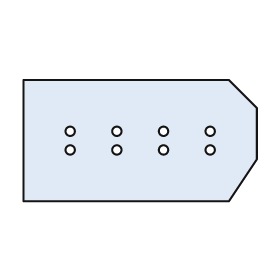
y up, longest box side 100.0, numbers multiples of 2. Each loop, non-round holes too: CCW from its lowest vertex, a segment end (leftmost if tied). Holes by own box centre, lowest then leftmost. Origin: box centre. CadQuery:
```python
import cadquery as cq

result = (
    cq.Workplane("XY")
    .moveTo(-50.0, -26.0)
    .lineTo(38.0, -26.0)
    .lineTo(50.0, -8.0)
    .lineTo(50.0, 14.0)
    .lineTo(38.0, 26.0)
    .lineTo(-50.0, 26.0)
    .close()
    .moveTo(-30.0, -4.0)
    .circle(2.0)
    .moveTo(-10.0, -4.0)
    .circle(2.0)
    .moveTo(10.0, -4.0)
    .circle(2.0)
    .moveTo(30.0, -4.0)
    .circle(2.0)
    .moveTo(-30.0, 4.0)
    .circle(2.0)
    .moveTo(-10.0, 4.0)
    .circle(2.0)
    .moveTo(10.0, 4.0)
    .circle(2.0)
    .moveTo(30.0, 4.0)
    .circle(2.0)
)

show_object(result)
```